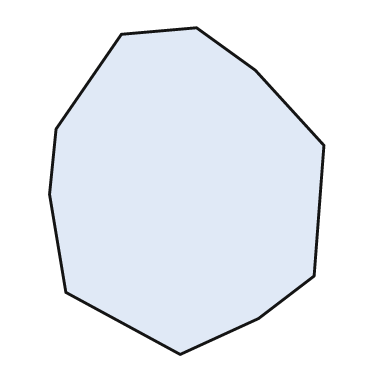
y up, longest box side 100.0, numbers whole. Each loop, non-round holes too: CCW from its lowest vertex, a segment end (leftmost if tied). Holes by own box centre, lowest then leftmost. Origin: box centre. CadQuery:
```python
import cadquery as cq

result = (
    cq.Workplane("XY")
    .moveTo(-2.0, -50.0)
    .lineTo(22.0, -39.0)
    .lineTo(39.0, -26.0)
    .lineTo(42.0, 14.0)
    .lineTo(21.0, 37.0)
    .lineTo(3.0, 50.0)
    .lineTo(-20.0, 48.0)
    .lineTo(-40.0, 19.0)
    .lineTo(-42.0, -1.0)
    .lineTo(-37.0, -31.0)
    .close()
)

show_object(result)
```